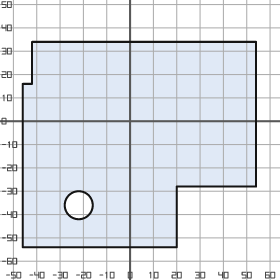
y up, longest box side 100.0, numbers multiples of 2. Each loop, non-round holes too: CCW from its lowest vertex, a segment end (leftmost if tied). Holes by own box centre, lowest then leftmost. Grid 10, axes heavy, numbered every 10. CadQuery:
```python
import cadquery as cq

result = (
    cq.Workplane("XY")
    .moveTo(-46.0, -54.0)
    .lineTo(20.0, -54.0)
    .lineTo(20.0, -28.0)
    .lineTo(54.0, -28.0)
    .lineTo(54.0, 34.0)
    .lineTo(-42.0, 34.0)
    .lineTo(-42.0, 16.0)
    .lineTo(-46.0, 16.0)
    .close()
    .moveTo(-22.0, -36.0)
    .circle(6.0)
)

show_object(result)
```